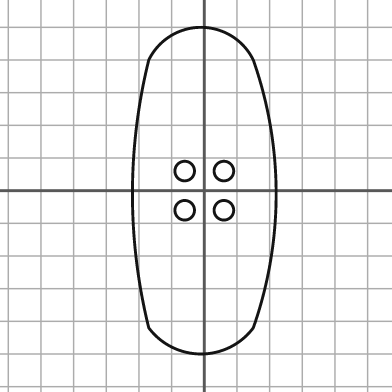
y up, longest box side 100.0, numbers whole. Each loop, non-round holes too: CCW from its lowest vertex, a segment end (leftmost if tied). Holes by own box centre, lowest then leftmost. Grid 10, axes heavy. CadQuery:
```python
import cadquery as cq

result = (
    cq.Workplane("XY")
    .moveTo(-17.0, -42.0)
    .threePointArc((-1.0, -50.0), (15.0, -42.0))
    .threePointArc((22.0, -1.0), (15.0, 40.0))
    .threePointArc((-1.0, 50.0), (-17.0, 40.0))
    .threePointArc((-22.0, -1.0), (-17.0, -42.0))
    .close()
    .moveTo(-6.0, -6.0)
    .circle(3.0)
    .moveTo(6.0, -6.0)
    .circle(3.0)
    .moveTo(-6.0, 6.0)
    .circle(3.0)
    .moveTo(6.0, 6.0)
    .circle(3.0)
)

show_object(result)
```